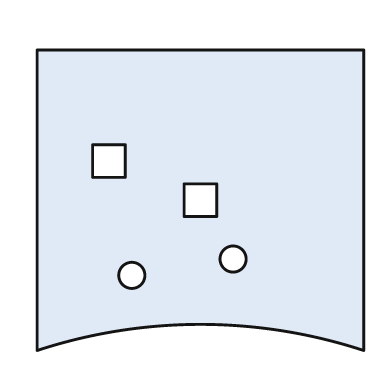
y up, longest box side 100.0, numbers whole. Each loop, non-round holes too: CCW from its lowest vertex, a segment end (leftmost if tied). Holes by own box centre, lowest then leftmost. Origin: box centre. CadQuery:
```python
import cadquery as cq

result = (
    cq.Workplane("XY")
    .moveTo(-50.0, -46.0)
    .threePointArc((0.0, -38.0), (50.0, -46.0))
    .lineTo(50.0, 46.0)
    .lineTo(-50.0, 46.0)
    .close()
    .moveTo(-21.0, -23.0)
    .circle(4.0)
    .moveTo(10.0, -18.0)
    .circle(4.0)
    .moveTo(-5.0, -5.0)
    .lineTo(5.0, -5.0)
    .lineTo(5.0, 5.0)
    .lineTo(-5.0, 5.0)
    .close()
    .moveTo(-33.0, 7.0)
    .lineTo(-23.0, 7.0)
    .lineTo(-23.0, 17.0)
    .lineTo(-33.0, 17.0)
    .close()
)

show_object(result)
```